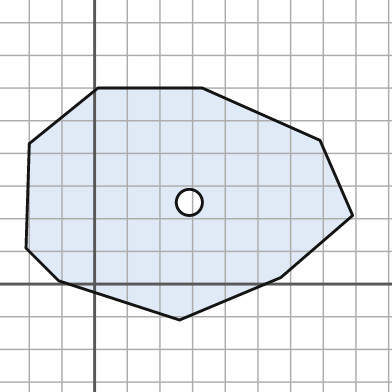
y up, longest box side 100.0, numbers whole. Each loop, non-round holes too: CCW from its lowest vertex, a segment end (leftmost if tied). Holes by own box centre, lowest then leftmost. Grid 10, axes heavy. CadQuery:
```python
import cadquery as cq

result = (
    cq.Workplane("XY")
    .moveTo(26.0, -11.0)
    .lineTo(57.0, 2.0)
    .lineTo(79.0, 21.0)
    .lineTo(69.0, 44.0)
    .lineTo(33.0, 60.0)
    .lineTo(1.0, 60.0)
    .lineTo(-20.0, 43.0)
    .lineTo(-21.0, 11.0)
    .lineTo(-11.0, 1.0)
    .close()
    .moveTo(29.0, 25.0)
    .circle(4.0)
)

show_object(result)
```